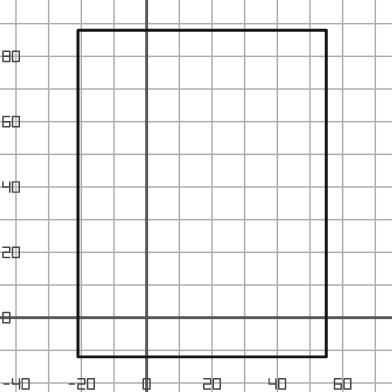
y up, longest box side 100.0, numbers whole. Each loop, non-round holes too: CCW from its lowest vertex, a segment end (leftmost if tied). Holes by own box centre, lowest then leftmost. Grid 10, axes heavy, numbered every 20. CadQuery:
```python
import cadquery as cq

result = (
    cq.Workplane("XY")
    .moveTo(-21.0, -12.0)
    .lineTo(55.0, -12.0)
    .lineTo(55.0, 88.0)
    .lineTo(-21.0, 88.0)
    .close()
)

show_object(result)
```